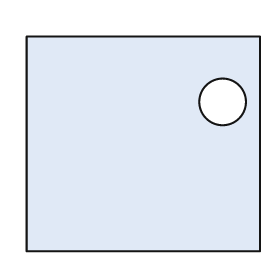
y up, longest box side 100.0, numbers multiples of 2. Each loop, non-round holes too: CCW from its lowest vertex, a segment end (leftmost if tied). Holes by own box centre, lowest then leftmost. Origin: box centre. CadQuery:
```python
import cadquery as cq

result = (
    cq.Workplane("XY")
    .moveTo(-50.0, -46.0)
    .lineTo(50.0, -46.0)
    .lineTo(50.0, 46.0)
    .lineTo(-50.0, 46.0)
    .close()
    .moveTo(34.0, 18.0)
    .circle(10.0)
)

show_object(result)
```